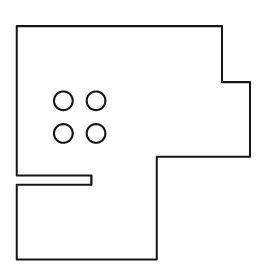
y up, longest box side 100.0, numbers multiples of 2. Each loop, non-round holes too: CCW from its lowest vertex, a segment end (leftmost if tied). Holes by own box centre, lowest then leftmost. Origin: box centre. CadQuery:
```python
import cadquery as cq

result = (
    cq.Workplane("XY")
    .moveTo(-50.0, -50.0)
    .lineTo(10.0, -50.0)
    .lineTo(10.0, -6.0)
    .lineTo(50.0, -6.0)
    .lineTo(50.0, 26.0)
    .lineTo(38.0, 26.0)
    .lineTo(38.0, 50.0)
    .lineTo(-50.0, 50.0)
    .lineTo(-50.0, -14.0)
    .lineTo(-18.0, -14.0)
    .lineTo(-18.0, -18.0)
    .lineTo(-50.0, -18.0)
    .close()
    .moveTo(-30.0, 4.0)
    .circle(4.0)
    .moveTo(-16.0, 4.0)
    .circle(4.0)
    .moveTo(-30.0, 18.0)
    .circle(4.0)
    .moveTo(-16.0, 18.0)
    .circle(4.0)
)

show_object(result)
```